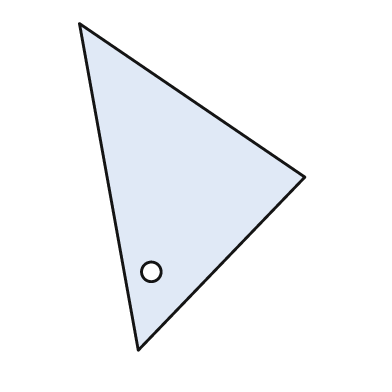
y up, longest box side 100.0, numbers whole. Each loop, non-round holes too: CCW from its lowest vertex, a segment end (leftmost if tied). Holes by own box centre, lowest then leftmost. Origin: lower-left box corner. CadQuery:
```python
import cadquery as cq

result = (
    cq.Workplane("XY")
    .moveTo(18.0, 0.0)
    .lineTo(69.0, 53.0)
    .lineTo(0.0, 100.0)
    .close()
    .moveTo(22.0, 24.0)
    .circle(3.0)
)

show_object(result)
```